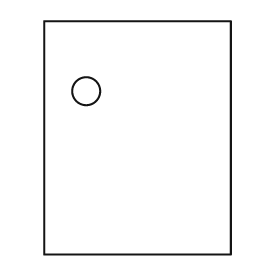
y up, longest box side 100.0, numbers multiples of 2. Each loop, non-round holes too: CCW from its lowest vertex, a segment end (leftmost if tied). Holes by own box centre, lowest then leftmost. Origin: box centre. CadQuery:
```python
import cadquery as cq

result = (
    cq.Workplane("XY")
    .moveTo(-40.0, -50.0)
    .lineTo(40.0, -50.0)
    .lineTo(40.0, 50.0)
    .lineTo(-40.0, 50.0)
    .close()
    .moveTo(-22.0, 20.0)
    .circle(6.0)
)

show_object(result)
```